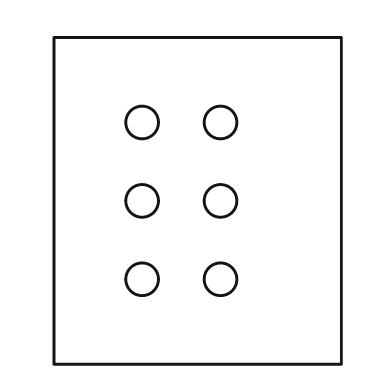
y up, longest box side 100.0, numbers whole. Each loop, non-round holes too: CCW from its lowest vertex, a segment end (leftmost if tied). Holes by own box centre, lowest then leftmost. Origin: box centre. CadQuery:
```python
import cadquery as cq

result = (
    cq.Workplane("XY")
    .moveTo(-44.0, -50.0)
    .lineTo(44.0, -50.0)
    .lineTo(44.0, 50.0)
    .lineTo(-44.0, 50.0)
    .close()
    .moveTo(-17.0, -24.0)
    .circle(5.0)
    .moveTo(7.0, -24.0)
    .circle(5.0)
    .moveTo(-17.0, 0.0)
    .circle(5.0)
    .moveTo(7.0, 0.0)
    .circle(5.0)
    .moveTo(-17.0, 24.0)
    .circle(5.0)
    .moveTo(7.0, 24.0)
    .circle(5.0)
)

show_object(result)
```